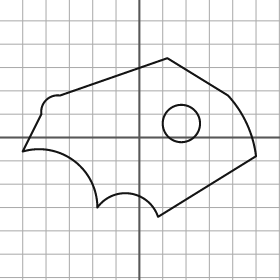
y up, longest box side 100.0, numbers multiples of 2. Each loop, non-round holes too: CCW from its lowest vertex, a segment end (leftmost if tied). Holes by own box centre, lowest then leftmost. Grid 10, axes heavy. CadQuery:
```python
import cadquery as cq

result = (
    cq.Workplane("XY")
    .moveTo(8.0, -34.0)
    .lineTo(50.0, -8.0)
    .threePointArc((46.0, 6.0), (38.0, 18.0))
    .lineTo(12.0, 34.0)
    .lineTo(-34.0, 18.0)
    .threePointArc((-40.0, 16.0), (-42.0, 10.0))
    .lineTo(-50.0, -6.0)
    .threePointArc((-28.0, -10.0), (-18.0, -30.0))
    .threePointArc((-4.0, -24.0), (8.0, -34.0))
    .close()
    .moveTo(18.0, 6.0)
    .circle(8.0)
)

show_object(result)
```